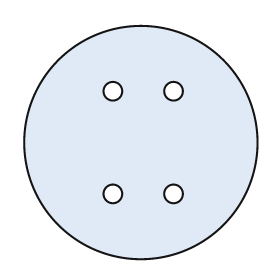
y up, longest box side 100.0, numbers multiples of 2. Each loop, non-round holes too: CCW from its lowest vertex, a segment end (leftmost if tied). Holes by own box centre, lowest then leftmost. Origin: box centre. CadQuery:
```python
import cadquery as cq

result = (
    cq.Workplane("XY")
    .moveTo(0.0, 0.0)
    .circle(50.0)
    .moveTo(-12.0, -22.0)
    .circle(4.0)
    .moveTo(14.0, -22.0)
    .circle(4.0)
    .moveTo(-12.0, 22.0)
    .circle(4.0)
    .moveTo(14.0, 22.0)
    .circle(4.0)
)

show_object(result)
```